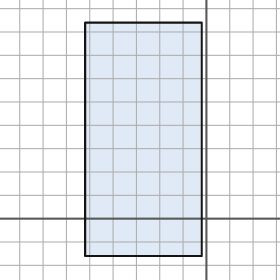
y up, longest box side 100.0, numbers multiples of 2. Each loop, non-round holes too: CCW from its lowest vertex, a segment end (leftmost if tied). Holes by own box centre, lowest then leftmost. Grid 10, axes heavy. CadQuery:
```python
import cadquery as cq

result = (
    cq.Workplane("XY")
    .moveTo(-52.0, -16.0)
    .lineTo(-2.0, -16.0)
    .lineTo(-2.0, 84.0)
    .lineTo(-52.0, 84.0)
    .close()
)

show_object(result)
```